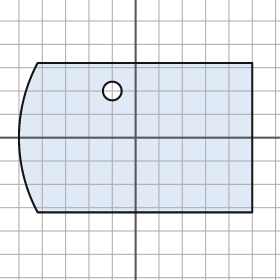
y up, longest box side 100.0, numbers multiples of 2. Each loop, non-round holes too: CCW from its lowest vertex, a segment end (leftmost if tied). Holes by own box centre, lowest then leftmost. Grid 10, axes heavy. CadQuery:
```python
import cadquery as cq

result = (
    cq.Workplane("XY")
    .moveTo(-42.0, -32.0)
    .lineTo(50.0, -32.0)
    .lineTo(50.0, 32.0)
    .lineTo(-42.0, 32.0)
    .threePointArc((-50.0, 0.0), (-42.0, -32.0))
    .close()
    .moveTo(-10.0, 20.0)
    .circle(4.0)
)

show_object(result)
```